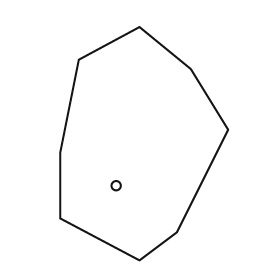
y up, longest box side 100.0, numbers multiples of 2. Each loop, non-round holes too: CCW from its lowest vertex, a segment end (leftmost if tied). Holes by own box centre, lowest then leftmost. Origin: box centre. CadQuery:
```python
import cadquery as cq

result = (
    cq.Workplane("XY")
    .moveTo(-2.0, -50.0)
    .lineTo(14.0, -38.0)
    .lineTo(36.0, 6.0)
    .lineTo(20.0, 32.0)
    .lineTo(-2.0, 50.0)
    .lineTo(-28.0, 36.0)
    .lineTo(-36.0, -4.0)
    .lineTo(-36.0, -32.0)
    .close()
    .moveTo(-12.0, -18.0)
    .circle(2.0)
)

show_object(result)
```